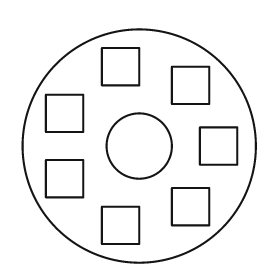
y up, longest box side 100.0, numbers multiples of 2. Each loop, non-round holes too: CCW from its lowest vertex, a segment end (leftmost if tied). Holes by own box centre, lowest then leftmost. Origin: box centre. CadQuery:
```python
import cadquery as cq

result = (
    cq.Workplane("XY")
    .moveTo(0.0, 0.0)
    .circle(50.0)
    .moveTo(-16.0, -42.0)
    .lineTo(0.0, -42.0)
    .lineTo(0.0, -26.0)
    .lineTo(-16.0, -26.0)
    .close()
    .moveTo(14.0, -34.0)
    .lineTo(30.0, -34.0)
    .lineTo(30.0, -18.0)
    .lineTo(14.0, -18.0)
    .close()
    .moveTo(-40.0, -22.0)
    .lineTo(-24.0, -22.0)
    .lineTo(-24.0, -6.0)
    .lineTo(-40.0, -6.0)
    .close()
    .moveTo(0.0, 0.0)
    .circle(14.0)
    .moveTo(26.0, -8.0)
    .lineTo(42.0, -8.0)
    .lineTo(42.0, 8.0)
    .lineTo(26.0, 8.0)
    .close()
    .moveTo(-40.0, 6.0)
    .lineTo(-24.0, 6.0)
    .lineTo(-24.0, 22.0)
    .lineTo(-40.0, 22.0)
    .close()
    .moveTo(14.0, 18.0)
    .lineTo(30.0, 18.0)
    .lineTo(30.0, 34.0)
    .lineTo(14.0, 34.0)
    .close()
    .moveTo(-16.0, 26.0)
    .lineTo(0.0, 26.0)
    .lineTo(0.0, 42.0)
    .lineTo(-16.0, 42.0)
    .close()
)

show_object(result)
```